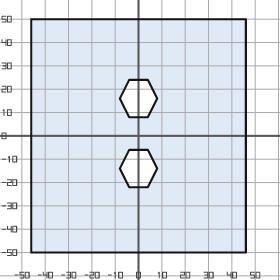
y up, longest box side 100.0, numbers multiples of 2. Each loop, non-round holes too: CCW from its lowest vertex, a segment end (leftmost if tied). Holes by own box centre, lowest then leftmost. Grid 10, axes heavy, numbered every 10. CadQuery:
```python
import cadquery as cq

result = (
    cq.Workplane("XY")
    .moveTo(-46.0, -50.0)
    .lineTo(46.0, -50.0)
    .lineTo(46.0, 50.0)
    .lineTo(-46.0, 50.0)
    .close()
    .moveTo(-4.0, -22.0)
    .lineTo(4.0, -22.0)
    .lineTo(8.0, -14.0)
    .lineTo(4.0, -6.0)
    .lineTo(-4.0, -6.0)
    .lineTo(-8.0, -14.0)
    .close()
    .moveTo(-4.0, 8.0)
    .lineTo(4.0, 8.0)
    .lineTo(8.0, 16.0)
    .lineTo(4.0, 24.0)
    .lineTo(-4.0, 24.0)
    .lineTo(-8.0, 16.0)
    .close()
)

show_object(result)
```